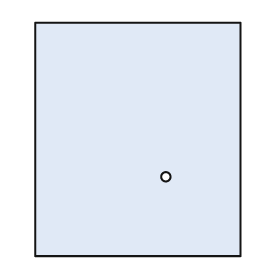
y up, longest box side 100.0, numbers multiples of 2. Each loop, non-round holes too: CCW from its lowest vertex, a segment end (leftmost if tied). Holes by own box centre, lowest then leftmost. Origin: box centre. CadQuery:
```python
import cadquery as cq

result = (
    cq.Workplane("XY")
    .moveTo(-44.0, -50.0)
    .lineTo(44.0, -50.0)
    .lineTo(44.0, 50.0)
    .lineTo(-44.0, 50.0)
    .close()
    .moveTo(12.0, -16.0)
    .circle(2.0)
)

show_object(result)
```